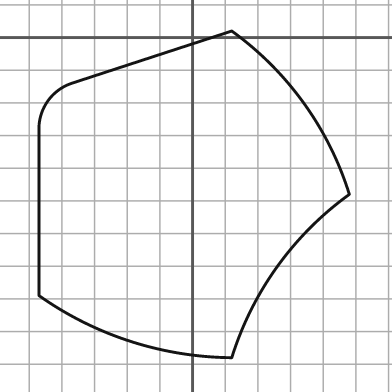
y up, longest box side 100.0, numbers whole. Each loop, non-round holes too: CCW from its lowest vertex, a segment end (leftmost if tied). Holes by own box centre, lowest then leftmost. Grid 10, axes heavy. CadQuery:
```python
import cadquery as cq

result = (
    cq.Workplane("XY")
    .moveTo(12.0, -98.0)
    .threePointArc((26.0, -70.0), (48.0, -48.0))
    .threePointArc((34.0, -20.0), (12.0, 2.0))
    .lineTo(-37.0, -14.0)
    .threePointArc((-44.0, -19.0), (-47.0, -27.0))
    .lineTo(-47.0, -79.0)
    .threePointArc((-19.0, -93.0), (12.0, -98.0))
    .close()
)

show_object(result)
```